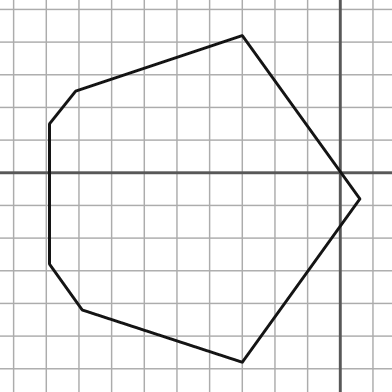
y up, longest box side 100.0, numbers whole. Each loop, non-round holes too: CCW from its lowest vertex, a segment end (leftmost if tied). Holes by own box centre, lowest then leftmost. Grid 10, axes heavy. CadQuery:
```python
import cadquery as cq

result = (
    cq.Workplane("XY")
    .moveTo(-30.0, -58.0)
    .lineTo(6.0, -8.0)
    .lineTo(-30.0, 42.0)
    .lineTo(-81.0, 25.0)
    .lineTo(-89.0, 15.0)
    .lineTo(-89.0, -28.0)
    .lineTo(-79.0, -42.0)
    .close()
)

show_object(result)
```